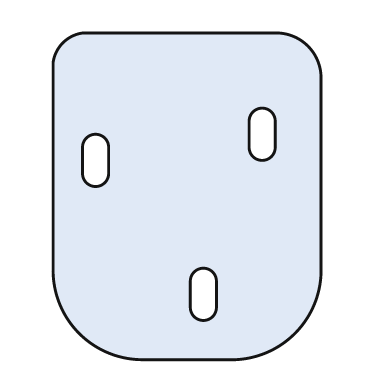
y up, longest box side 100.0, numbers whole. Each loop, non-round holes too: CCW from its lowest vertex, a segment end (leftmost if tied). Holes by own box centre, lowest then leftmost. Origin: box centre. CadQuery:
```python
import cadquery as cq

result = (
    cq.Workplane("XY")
    .moveTo(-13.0, -50.0)
    .lineTo(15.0, -50.0)
    .threePointArc((33.0, -42.0), (41.0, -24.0))
    .lineTo(41.0, 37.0)
    .threePointArc((37.0, 46.0), (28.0, 50.0))
    .lineTo(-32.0, 50.0)
    .threePointArc((-38.0, 47.0), (-41.0, 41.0))
    .lineTo(-41.0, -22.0)
    .threePointArc((-33.0, -42.0), (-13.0, -50.0))
    .close()
    .moveTo(1.0, -34.0)
    .threePointArc((5.0, -38.0), (9.0, -34.0))
    .lineTo(9.0, -26.0)
    .threePointArc((5.0, -22.0), (1.0, -26.0))
    .close()
    .moveTo(-32.0, 7.0)
    .threePointArc((-28.0, 3.0), (-24.0, 7.0))
    .lineTo(-24.0, 15.0)
    .threePointArc((-28.0, 19.0), (-32.0, 15.0))
    .close()
    .moveTo(19.0, 15.0)
    .threePointArc((23.0, 11.0), (27.0, 15.0))
    .lineTo(27.0, 23.0)
    .threePointArc((23.0, 27.0), (19.0, 23.0))
    .close()
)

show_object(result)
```